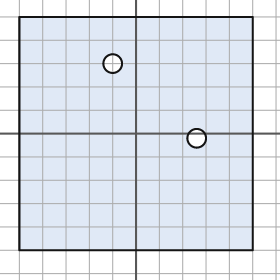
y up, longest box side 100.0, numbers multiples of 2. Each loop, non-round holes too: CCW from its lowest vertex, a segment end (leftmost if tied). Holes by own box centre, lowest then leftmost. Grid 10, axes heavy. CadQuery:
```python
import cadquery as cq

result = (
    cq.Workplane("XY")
    .moveTo(-50.0, -50.0)
    .lineTo(50.0, -50.0)
    .lineTo(50.0, 50.0)
    .lineTo(-50.0, 50.0)
    .close()
    .moveTo(26.0, -2.0)
    .circle(4.0)
    .moveTo(-10.0, 30.0)
    .circle(4.0)
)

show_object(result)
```